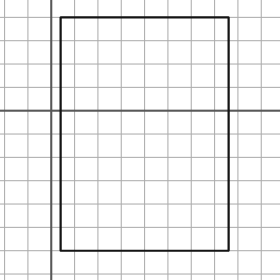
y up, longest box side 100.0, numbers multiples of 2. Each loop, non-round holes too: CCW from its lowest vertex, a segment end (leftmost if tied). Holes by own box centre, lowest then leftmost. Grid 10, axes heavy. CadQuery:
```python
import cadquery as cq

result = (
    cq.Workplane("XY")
    .moveTo(4.0, -60.0)
    .lineTo(76.0, -60.0)
    .lineTo(76.0, 40.0)
    .lineTo(4.0, 40.0)
    .close()
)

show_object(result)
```